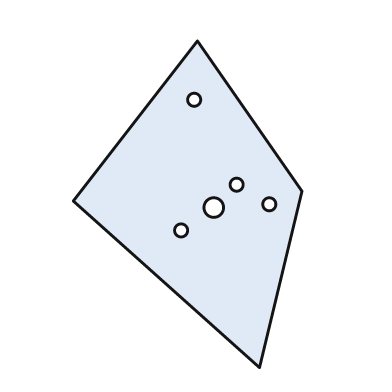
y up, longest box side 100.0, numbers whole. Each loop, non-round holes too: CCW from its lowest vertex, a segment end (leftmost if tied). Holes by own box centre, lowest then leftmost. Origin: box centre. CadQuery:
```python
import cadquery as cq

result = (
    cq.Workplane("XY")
    .moveTo(22.0, -50.0)
    .lineTo(35.0, 4.0)
    .lineTo(3.0, 50.0)
    .lineTo(-35.0, 1.0)
    .close()
    .moveTo(-2.0, -8.0)
    .circle(2.0)
    .moveTo(8.0, -1.0)
    .circle(3.0)
    .moveTo(25.0, 0.0)
    .circle(2.0)
    .moveTo(15.0, 6.0)
    .circle(2.0)
    .moveTo(2.0, 32.0)
    .circle(2.0)
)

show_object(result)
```